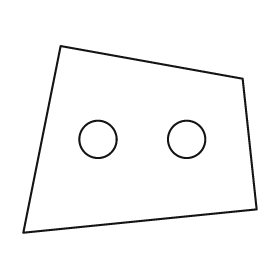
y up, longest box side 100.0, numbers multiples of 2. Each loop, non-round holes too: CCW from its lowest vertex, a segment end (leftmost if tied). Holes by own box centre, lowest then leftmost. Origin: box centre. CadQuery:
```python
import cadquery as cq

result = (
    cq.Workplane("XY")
    .moveTo(-50.0, -40.0)
    .lineTo(50.0, -30.0)
    .lineTo(44.0, 26.0)
    .lineTo(-34.0, 40.0)
    .close()
    .moveTo(-18.0, 0.0)
    .circle(8.0)
    .moveTo(20.0, 0.0)
    .circle(8.0)
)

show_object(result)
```